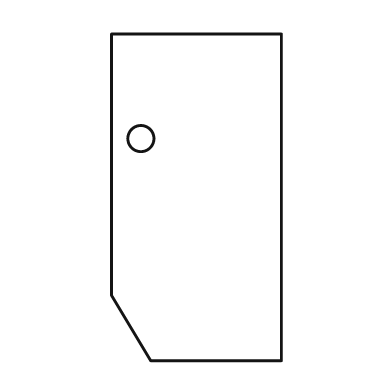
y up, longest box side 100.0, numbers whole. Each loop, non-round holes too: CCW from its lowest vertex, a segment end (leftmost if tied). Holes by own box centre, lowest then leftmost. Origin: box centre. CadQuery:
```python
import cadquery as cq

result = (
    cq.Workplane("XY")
    .moveTo(-14.0, -50.0)
    .lineTo(26.0, -50.0)
    .lineTo(26.0, 50.0)
    .lineTo(-26.0, 50.0)
    .lineTo(-26.0, -30.0)
    .close()
    .moveTo(-17.0, 18.0)
    .circle(4.0)
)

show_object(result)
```